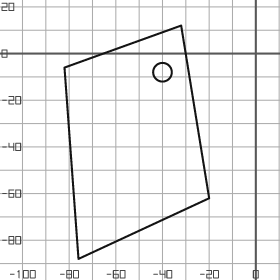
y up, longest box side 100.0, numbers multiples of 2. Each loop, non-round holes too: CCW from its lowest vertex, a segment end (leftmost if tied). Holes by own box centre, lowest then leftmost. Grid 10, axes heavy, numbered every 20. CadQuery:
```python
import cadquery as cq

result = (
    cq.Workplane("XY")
    .moveTo(-76.0, -88.0)
    .lineTo(-20.0, -62.0)
    .lineTo(-32.0, 12.0)
    .lineTo(-82.0, -6.0)
    .close()
    .moveTo(-40.0, -8.0)
    .circle(4.0)
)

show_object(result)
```